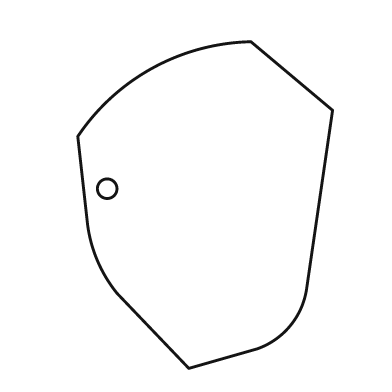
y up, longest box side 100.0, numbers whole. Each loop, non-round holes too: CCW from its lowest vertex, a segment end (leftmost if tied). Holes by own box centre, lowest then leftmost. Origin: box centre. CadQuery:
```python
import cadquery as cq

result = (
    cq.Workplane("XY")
    .moveTo(-5.0, -50.0)
    .lineTo(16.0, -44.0)
    .threePointArc((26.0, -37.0), (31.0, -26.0))
    .lineTo(39.0, 29.0)
    .lineTo(14.0, 50.0)
    .threePointArc((-16.0, 42.0), (-39.0, 21.0))
    .lineTo(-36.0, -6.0)
    .threePointArc((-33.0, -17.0), (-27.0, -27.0))
    .close()
    .moveTo(-30.0, 5.0)
    .circle(3.0)
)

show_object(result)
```